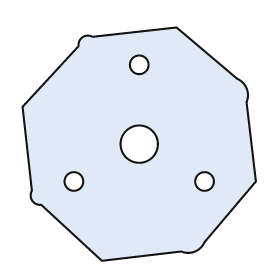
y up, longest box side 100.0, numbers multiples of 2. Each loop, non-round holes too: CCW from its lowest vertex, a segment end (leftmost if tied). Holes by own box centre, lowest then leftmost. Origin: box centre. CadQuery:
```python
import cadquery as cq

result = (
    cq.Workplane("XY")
    .moveTo(-16.0, -50.0)
    .lineTo(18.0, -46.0)
    .threePointArc((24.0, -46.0), (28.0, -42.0))
    .lineTo(50.0, -16.0)
    .lineTo(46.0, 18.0)
    .threePointArc((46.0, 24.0), (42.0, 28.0))
    .lineTo(16.0, 50.0)
    .lineTo(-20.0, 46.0)
    .threePointArc((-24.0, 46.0), (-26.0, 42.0))
    .lineTo(-50.0, 16.0)
    .lineTo(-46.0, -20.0)
    .threePointArc((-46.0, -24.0), (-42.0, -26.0))
    .close()
    .moveTo(-28.0, -16.0)
    .circle(4.0)
    .moveTo(28.0, -16.0)
    .circle(4.0)
    .moveTo(0.0, 0.0)
    .circle(8.0)
    .moveTo(0.0, 34.0)
    .circle(4.0)
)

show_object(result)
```